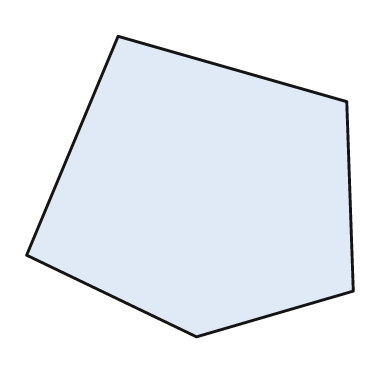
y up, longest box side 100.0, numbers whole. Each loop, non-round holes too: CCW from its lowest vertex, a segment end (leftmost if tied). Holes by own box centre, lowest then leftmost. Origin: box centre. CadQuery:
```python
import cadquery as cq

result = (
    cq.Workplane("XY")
    .moveTo(2.0, -46.0)
    .lineTo(50.0, -32.0)
    .lineTo(48.0, 26.0)
    .lineTo(-22.0, 46.0)
    .lineTo(-50.0, -21.0)
    .close()
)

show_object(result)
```